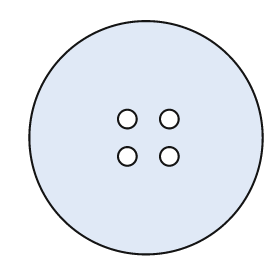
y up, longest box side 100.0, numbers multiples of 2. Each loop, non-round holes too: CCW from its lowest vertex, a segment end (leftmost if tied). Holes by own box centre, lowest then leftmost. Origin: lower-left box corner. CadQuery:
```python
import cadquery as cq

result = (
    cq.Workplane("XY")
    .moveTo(50.0, 50.0)
    .circle(50.0)
    .moveTo(42.0, 42.0)
    .circle(4.0)
    .moveTo(60.0, 42.0)
    .circle(4.0)
    .moveTo(42.0, 58.0)
    .circle(4.0)
    .moveTo(60.0, 58.0)
    .circle(4.0)
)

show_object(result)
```